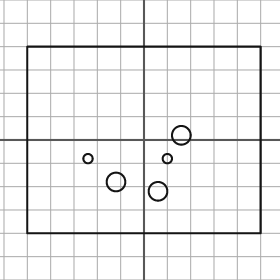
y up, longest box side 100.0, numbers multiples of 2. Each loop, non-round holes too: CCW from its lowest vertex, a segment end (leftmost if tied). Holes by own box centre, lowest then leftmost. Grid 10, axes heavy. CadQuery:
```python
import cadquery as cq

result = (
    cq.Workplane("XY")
    .moveTo(-50.0, -40.0)
    .lineTo(50.0, -40.0)
    .lineTo(50.0, 40.0)
    .lineTo(-50.0, 40.0)
    .close()
    .moveTo(6.0, -22.0)
    .circle(4.0)
    .moveTo(-12.0, -18.0)
    .circle(4.0)
    .moveTo(-24.0, -8.0)
    .circle(2.0)
    .moveTo(10.0, -8.0)
    .circle(2.0)
    .moveTo(16.0, 2.0)
    .circle(4.0)
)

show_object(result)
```